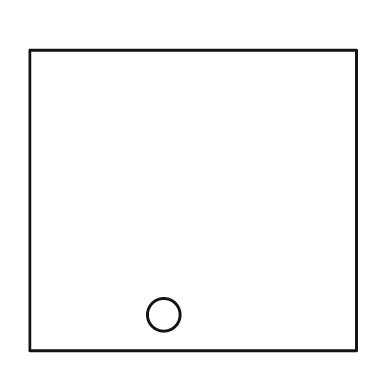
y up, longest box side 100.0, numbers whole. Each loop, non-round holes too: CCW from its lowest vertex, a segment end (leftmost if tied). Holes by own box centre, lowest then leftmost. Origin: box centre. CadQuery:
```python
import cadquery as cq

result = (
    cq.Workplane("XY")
    .moveTo(-50.0, -46.0)
    .lineTo(50.0, -46.0)
    .lineTo(50.0, 46.0)
    .lineTo(-50.0, 46.0)
    .close()
    .moveTo(-9.0, -35.0)
    .circle(5.0)
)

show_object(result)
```